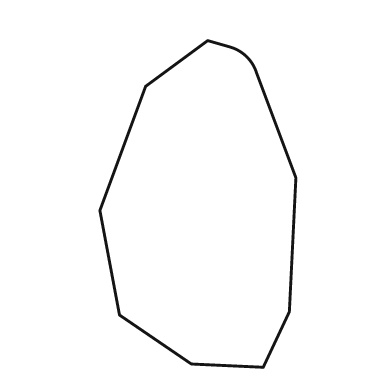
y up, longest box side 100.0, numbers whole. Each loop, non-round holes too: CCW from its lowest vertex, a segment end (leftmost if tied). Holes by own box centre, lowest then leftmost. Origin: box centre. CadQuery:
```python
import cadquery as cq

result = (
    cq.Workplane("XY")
    .moveTo(20.0, -50.0)
    .lineTo(28.0, -33.0)
    .lineTo(30.0, 8.0)
    .lineTo(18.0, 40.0)
    .threePointArc((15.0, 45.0), (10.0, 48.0))
    .lineTo(3.0, 50.0)
    .lineTo(-16.0, 36.0)
    .lineTo(-30.0, -2.0)
    .lineTo(-24.0, -34.0)
    .lineTo(-2.0, -49.0)
    .close()
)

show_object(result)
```